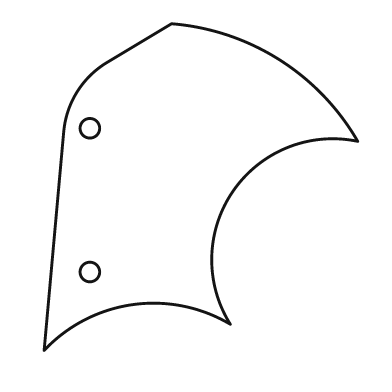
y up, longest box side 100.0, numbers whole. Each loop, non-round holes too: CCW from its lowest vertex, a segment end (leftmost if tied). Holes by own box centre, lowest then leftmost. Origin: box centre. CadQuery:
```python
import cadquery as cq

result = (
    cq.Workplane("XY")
    .moveTo(-48.0, -50.0)
    .threePointArc((-21.0, -36.0), (9.0, -42.0))
    .threePointArc((10.0, -1.0), (48.0, 14.0))
    .threePointArc((24.0, 39.0), (-9.0, 50.0))
    .lineTo(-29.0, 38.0)
    .threePointArc((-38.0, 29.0), (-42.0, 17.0))
    .close()
    .moveTo(-34.0, -26.0)
    .circle(3.0)
    .moveTo(-34.0, 18.0)
    .circle(3.0)
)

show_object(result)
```